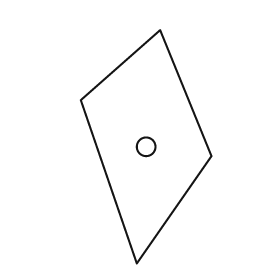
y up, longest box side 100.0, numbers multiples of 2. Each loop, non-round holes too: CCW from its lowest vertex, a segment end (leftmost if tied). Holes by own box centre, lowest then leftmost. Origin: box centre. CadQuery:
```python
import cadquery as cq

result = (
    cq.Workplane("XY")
    .moveTo(-4.0, -50.0)
    .lineTo(28.0, -4.0)
    .lineTo(6.0, 50.0)
    .lineTo(-28.0, 20.0)
    .close()
    .moveTo(0.0, 0.0)
    .circle(4.0)
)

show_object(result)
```